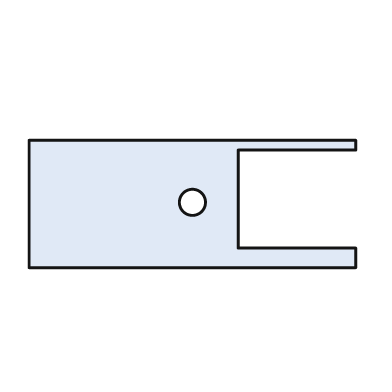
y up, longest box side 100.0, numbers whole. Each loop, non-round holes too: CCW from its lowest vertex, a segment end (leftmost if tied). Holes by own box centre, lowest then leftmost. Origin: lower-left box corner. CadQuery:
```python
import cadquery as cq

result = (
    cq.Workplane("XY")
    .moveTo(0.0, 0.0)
    .lineTo(100.0, 0.0)
    .lineTo(100.0, 6.0)
    .lineTo(64.0, 6.0)
    .lineTo(64.0, 36.0)
    .lineTo(100.0, 36.0)
    .lineTo(100.0, 39.0)
    .lineTo(0.0, 39.0)
    .close()
    .moveTo(50.0, 20.0)
    .circle(4.0)
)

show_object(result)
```